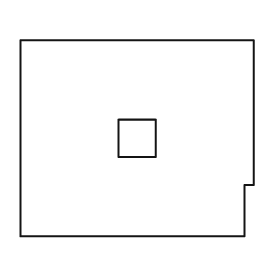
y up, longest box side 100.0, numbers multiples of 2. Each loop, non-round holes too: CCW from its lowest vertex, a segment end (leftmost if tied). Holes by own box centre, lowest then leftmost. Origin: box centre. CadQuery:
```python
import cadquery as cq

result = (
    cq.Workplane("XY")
    .moveTo(-50.0, -42.0)
    .lineTo(46.0, -42.0)
    .lineTo(46.0, -20.0)
    .lineTo(50.0, -20.0)
    .lineTo(50.0, 42.0)
    .lineTo(-50.0, 42.0)
    .close()
    .moveTo(-8.0, -8.0)
    .lineTo(8.0, -8.0)
    .lineTo(8.0, 8.0)
    .lineTo(-8.0, 8.0)
    .close()
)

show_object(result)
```